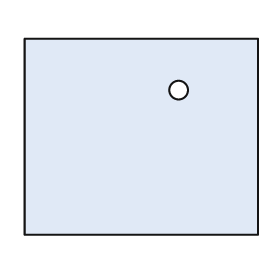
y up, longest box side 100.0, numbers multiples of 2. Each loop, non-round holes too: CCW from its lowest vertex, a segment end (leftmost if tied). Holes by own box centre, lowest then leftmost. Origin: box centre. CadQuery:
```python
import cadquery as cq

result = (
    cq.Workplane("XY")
    .moveTo(-50.0, -42.0)
    .lineTo(50.0, -42.0)
    .lineTo(50.0, 42.0)
    .lineTo(-50.0, 42.0)
    .close()
    .moveTo(16.0, 20.0)
    .circle(4.0)
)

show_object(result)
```